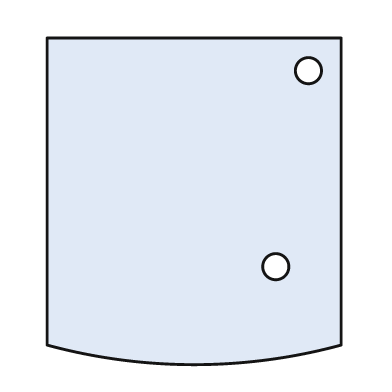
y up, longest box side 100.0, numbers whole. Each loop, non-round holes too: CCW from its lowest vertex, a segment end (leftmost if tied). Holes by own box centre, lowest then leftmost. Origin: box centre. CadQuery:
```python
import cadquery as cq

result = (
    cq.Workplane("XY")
    .moveTo(-45.0, -44.0)
    .threePointArc((0.0, -50.0), (45.0, -44.0))
    .lineTo(45.0, 50.0)
    .lineTo(-45.0, 50.0)
    .close()
    .moveTo(25.0, -20.0)
    .circle(4.0)
    .moveTo(35.0, 40.0)
    .circle(4.0)
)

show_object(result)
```